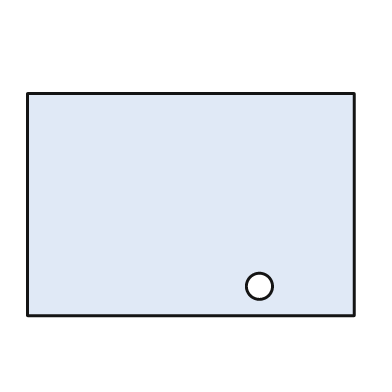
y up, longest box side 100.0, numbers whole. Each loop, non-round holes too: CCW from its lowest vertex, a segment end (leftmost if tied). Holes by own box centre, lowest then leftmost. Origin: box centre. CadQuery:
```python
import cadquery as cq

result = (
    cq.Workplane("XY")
    .moveTo(-50.0, -34.0)
    .lineTo(50.0, -34.0)
    .lineTo(50.0, 34.0)
    .lineTo(-50.0, 34.0)
    .close()
    .moveTo(21.0, -25.0)
    .circle(4.0)
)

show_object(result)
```